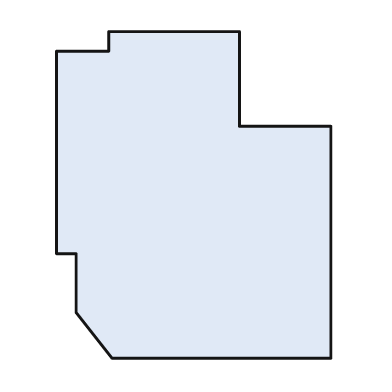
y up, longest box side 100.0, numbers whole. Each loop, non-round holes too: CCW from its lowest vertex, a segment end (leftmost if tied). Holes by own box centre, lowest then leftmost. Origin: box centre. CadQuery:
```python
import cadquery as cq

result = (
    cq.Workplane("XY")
    .moveTo(-25.0, -50.0)
    .lineTo(42.0, -50.0)
    .lineTo(42.0, 21.0)
    .lineTo(14.0, 21.0)
    .lineTo(14.0, 50.0)
    .lineTo(-26.0, 50.0)
    .lineTo(-26.0, 44.0)
    .lineTo(-42.0, 44.0)
    .lineTo(-42.0, -18.0)
    .lineTo(-36.0, -18.0)
    .lineTo(-36.0, -36.0)
    .close()
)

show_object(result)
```